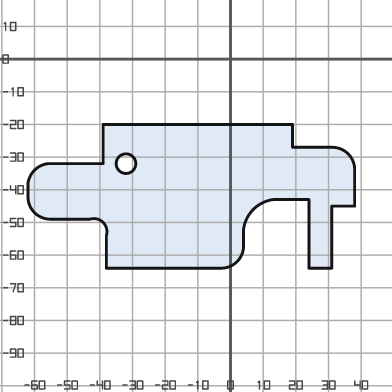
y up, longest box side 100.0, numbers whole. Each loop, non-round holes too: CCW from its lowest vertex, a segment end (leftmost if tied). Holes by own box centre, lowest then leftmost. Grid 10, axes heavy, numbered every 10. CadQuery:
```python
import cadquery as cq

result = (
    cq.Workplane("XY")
    .moveTo(-38.0, -64.0)
    .lineTo(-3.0, -64.0)
    .threePointArc((2.0, -62.0), (4.0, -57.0))
    .lineTo(4.0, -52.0)
    .threePointArc((7.0, -46.0), (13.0, -43.0))
    .lineTo(24.0, -43.0)
    .lineTo(24.0, -64.0)
    .lineTo(31.0, -64.0)
    .lineTo(31.0, -45.0)
    .lineTo(38.0, -45.0)
    .lineTo(38.0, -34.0)
    .threePointArc((36.0, -29.0), (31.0, -27.0))
    .lineTo(19.0, -27.0)
    .lineTo(19.0, -20.0)
    .lineTo(-39.0, -20.0)
    .lineTo(-39.0, -32.0)
    .lineTo(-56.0, -32.0)
    .threePointArc((-60.0, -34.0), (-62.0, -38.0))
    .lineTo(-62.0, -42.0)
    .threePointArc((-60.0, -47.0), (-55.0, -49.0))
    .lineTo(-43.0, -49.0)
    .threePointArc((-39.0, -50.0), (-38.0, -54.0))
    .close()
    .moveTo(-32.0, -32.0)
    .circle(3.0)
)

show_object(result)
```